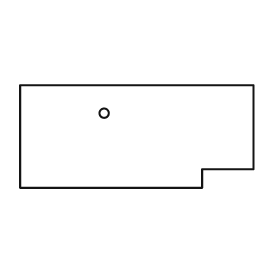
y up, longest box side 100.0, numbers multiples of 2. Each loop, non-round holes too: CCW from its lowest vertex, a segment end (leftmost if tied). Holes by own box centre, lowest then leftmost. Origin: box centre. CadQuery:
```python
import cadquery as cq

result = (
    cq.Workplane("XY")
    .moveTo(-50.0, -22.0)
    .lineTo(28.0, -22.0)
    .lineTo(28.0, -14.0)
    .lineTo(50.0, -14.0)
    .lineTo(50.0, 22.0)
    .lineTo(-50.0, 22.0)
    .close()
    .moveTo(-14.0, 10.0)
    .circle(2.0)
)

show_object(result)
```